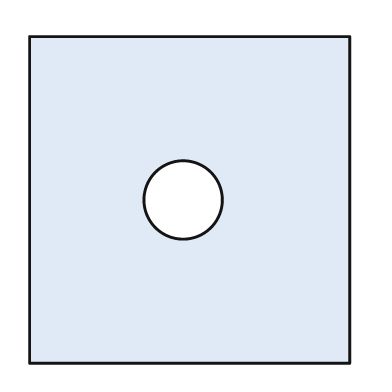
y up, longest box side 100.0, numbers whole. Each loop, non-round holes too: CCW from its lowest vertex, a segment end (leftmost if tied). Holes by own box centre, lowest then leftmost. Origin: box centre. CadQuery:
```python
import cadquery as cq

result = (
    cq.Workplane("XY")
    .moveTo(-49.0, -50.0)
    .lineTo(49.0, -50.0)
    .lineTo(49.0, 50.0)
    .lineTo(-49.0, 50.0)
    .close()
    .moveTo(-2.0, 0.0)
    .circle(12.0)
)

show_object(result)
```